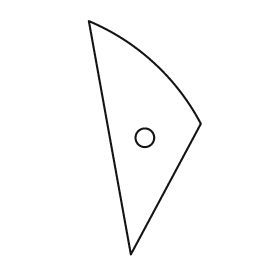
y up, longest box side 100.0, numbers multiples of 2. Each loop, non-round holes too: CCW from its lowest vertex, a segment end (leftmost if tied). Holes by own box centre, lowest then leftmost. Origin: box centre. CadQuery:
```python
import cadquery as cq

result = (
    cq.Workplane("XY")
    .moveTo(-6.0, -50.0)
    .lineTo(24.0, 6.0)
    .threePointArc((4.0, 32.0), (-24.0, 50.0))
    .close()
    .moveTo(0.0, 0.0)
    .circle(4.0)
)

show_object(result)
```